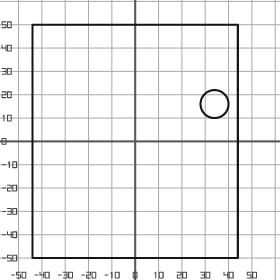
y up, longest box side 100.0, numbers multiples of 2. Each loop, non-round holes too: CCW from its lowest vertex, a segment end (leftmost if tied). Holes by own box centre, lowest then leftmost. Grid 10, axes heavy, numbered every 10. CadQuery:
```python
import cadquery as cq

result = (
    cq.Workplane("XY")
    .moveTo(-44.0, -50.0)
    .lineTo(44.0, -50.0)
    .lineTo(44.0, 50.0)
    .lineTo(-44.0, 50.0)
    .close()
    .moveTo(34.0, 16.0)
    .circle(6.0)
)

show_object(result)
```